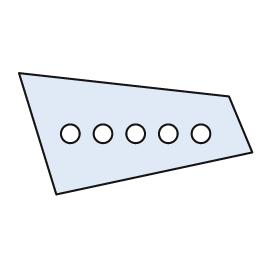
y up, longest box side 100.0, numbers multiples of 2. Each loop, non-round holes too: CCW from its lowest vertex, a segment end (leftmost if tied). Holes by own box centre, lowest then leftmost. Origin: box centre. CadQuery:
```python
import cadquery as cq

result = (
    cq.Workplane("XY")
    .moveTo(-34.0, -26.0)
    .lineTo(50.0, -8.0)
    .lineTo(40.0, 16.0)
    .lineTo(-50.0, 26.0)
    .close()
    .moveTo(-28.0, 0.0)
    .circle(4.0)
    .moveTo(-14.0, 0.0)
    .circle(4.0)
    .moveTo(0.0, 0.0)
    .circle(4.0)
    .moveTo(14.0, 0.0)
    .circle(4.0)
    .moveTo(28.0, 0.0)
    .circle(4.0)
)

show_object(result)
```